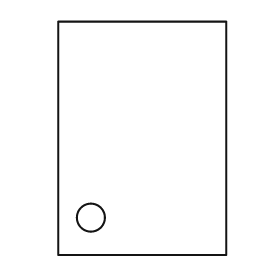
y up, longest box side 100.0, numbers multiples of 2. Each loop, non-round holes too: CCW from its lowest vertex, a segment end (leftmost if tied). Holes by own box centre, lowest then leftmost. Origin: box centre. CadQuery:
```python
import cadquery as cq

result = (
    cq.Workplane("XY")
    .moveTo(-36.0, -50.0)
    .lineTo(36.0, -50.0)
    .lineTo(36.0, 50.0)
    .lineTo(-36.0, 50.0)
    .close()
    .moveTo(-22.0, -34.0)
    .circle(6.0)
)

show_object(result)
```